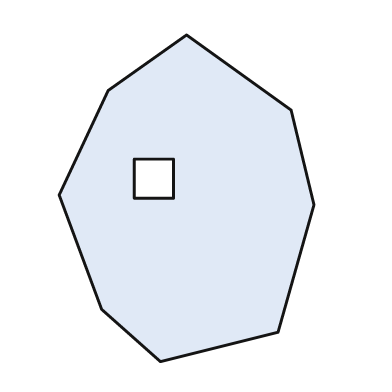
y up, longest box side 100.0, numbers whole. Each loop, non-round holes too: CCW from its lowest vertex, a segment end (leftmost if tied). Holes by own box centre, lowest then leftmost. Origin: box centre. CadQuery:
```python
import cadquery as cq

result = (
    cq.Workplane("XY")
    .moveTo(-8.0, -50.0)
    .lineTo(28.0, -41.0)
    .lineTo(39.0, -2.0)
    .lineTo(32.0, 27.0)
    .lineTo(0.0, 50.0)
    .lineTo(-24.0, 33.0)
    .lineTo(-39.0, 1.0)
    .lineTo(-26.0, -34.0)
    .close()
    .moveTo(-16.0, 0.0)
    .lineTo(-4.0, 0.0)
    .lineTo(-4.0, 12.0)
    .lineTo(-16.0, 12.0)
    .close()
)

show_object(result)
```